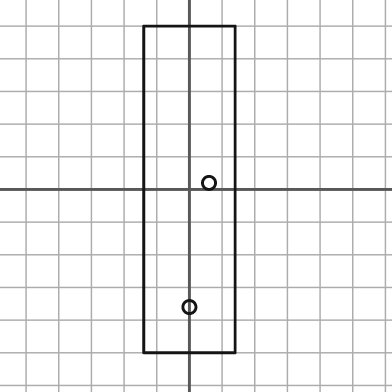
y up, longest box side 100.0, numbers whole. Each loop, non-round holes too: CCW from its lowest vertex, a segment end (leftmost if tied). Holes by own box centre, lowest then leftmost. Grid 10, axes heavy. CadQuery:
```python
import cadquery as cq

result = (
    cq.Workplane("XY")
    .moveTo(-14.0, -50.0)
    .lineTo(14.0, -50.0)
    .lineTo(14.0, 50.0)
    .lineTo(-14.0, 50.0)
    .close()
    .moveTo(0.0, -36.0)
    .circle(2.0)
    .moveTo(6.0, 2.0)
    .circle(2.0)
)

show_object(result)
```